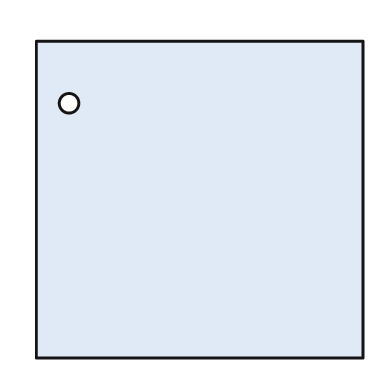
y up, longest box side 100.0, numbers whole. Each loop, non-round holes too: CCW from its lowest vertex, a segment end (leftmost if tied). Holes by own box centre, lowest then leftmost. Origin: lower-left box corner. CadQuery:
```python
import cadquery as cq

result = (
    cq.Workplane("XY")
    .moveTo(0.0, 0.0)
    .lineTo(100.0, 0.0)
    .lineTo(100.0, 97.0)
    .lineTo(0.0, 97.0)
    .close()
    .moveTo(10.0, 78.0)
    .circle(3.0)
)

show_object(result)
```